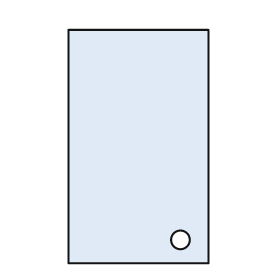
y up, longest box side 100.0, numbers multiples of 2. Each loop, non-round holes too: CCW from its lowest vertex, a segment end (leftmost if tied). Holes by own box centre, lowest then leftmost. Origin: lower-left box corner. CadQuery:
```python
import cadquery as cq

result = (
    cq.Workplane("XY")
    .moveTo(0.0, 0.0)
    .lineTo(60.0, 0.0)
    .lineTo(60.0, 100.0)
    .lineTo(0.0, 100.0)
    .close()
    .moveTo(48.0, 10.0)
    .circle(4.0)
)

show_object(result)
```